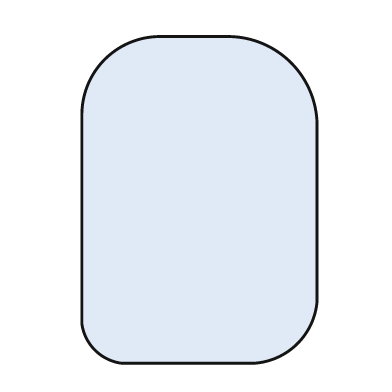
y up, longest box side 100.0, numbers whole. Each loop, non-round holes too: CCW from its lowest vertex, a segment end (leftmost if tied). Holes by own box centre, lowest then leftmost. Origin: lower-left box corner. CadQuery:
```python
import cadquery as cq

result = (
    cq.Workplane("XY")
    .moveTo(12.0, 0.0)
    .lineTo(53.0, 0.0)
    .threePointArc((66.0, 6.0), (72.0, 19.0))
    .lineTo(72.0, 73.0)
    .threePointArc((64.0, 92.0), (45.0, 100.0))
    .lineTo(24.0, 100.0)
    .threePointArc((7.0, 93.0), (0.0, 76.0))
    .lineTo(0.0, 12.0)
    .threePointArc((4.0, 4.0), (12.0, 0.0))
    .close()
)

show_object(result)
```